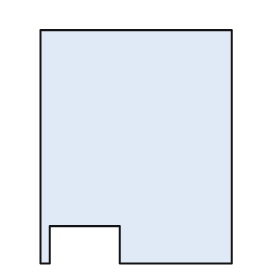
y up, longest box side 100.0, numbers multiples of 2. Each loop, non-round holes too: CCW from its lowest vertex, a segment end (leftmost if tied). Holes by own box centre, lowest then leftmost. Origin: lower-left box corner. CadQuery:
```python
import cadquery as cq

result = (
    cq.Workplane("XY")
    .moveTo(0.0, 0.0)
    .lineTo(4.0, 0.0)
    .lineTo(4.0, 16.0)
    .lineTo(34.0, 16.0)
    .lineTo(34.0, 0.0)
    .lineTo(82.0, 0.0)
    .lineTo(82.0, 100.0)
    .lineTo(0.0, 100.0)
    .close()
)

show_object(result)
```